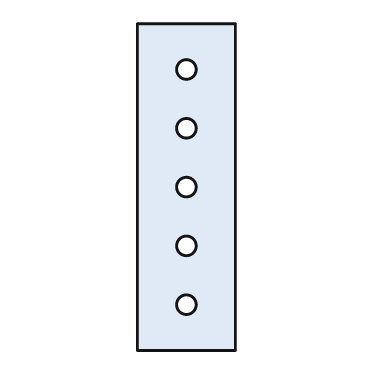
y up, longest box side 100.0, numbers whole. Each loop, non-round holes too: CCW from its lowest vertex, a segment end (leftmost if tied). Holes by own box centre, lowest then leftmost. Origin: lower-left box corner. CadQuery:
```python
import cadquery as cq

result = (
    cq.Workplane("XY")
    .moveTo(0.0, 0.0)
    .lineTo(30.0, 0.0)
    .lineTo(30.0, 100.0)
    .lineTo(0.0, 100.0)
    .close()
    .moveTo(15.0, 14.0)
    .circle(3.0)
    .moveTo(15.0, 32.0)
    .circle(3.0)
    .moveTo(15.0, 50.0)
    .circle(3.0)
    .moveTo(15.0, 68.0)
    .circle(3.0)
    .moveTo(15.0, 86.0)
    .circle(3.0)
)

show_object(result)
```